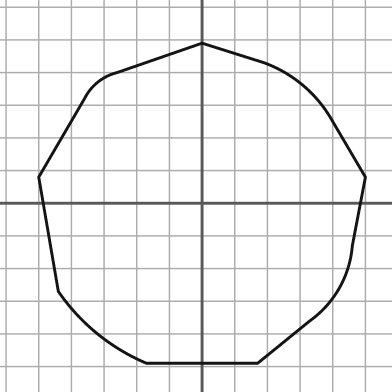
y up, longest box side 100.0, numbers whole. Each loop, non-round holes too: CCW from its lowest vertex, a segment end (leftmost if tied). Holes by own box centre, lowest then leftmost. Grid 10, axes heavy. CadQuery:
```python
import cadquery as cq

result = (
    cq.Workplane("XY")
    .moveTo(-17.0, -49.0)
    .lineTo(17.0, -49.0)
    .lineTo(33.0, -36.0)
    .threePointArc((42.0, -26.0), (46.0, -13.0))
    .lineTo(50.0, 8.0)
    .lineTo(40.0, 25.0)
    .threePointArc((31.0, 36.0), (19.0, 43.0))
    .lineTo(0.0, 49.0)
    .lineTo(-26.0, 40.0)
    .threePointArc((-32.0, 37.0), (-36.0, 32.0))
    .lineTo(-50.0, 8.0)
    .lineTo(-44.0, -27.0)
    .threePointArc((-32.0, -40.0), (-17.0, -49.0))
    .close()
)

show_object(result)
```